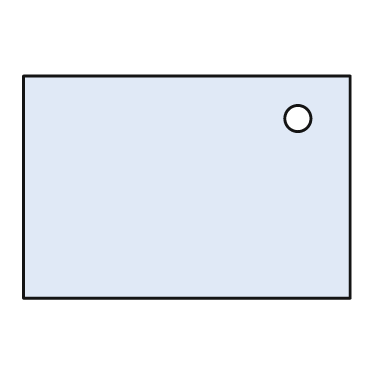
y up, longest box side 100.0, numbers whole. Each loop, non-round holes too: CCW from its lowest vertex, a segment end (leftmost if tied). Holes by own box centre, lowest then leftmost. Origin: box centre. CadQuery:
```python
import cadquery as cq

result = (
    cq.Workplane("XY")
    .moveTo(-50.0, -34.0)
    .lineTo(50.0, -34.0)
    .lineTo(50.0, 34.0)
    .lineTo(-50.0, 34.0)
    .close()
    .moveTo(34.0, 21.0)
    .circle(4.0)
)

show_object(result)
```